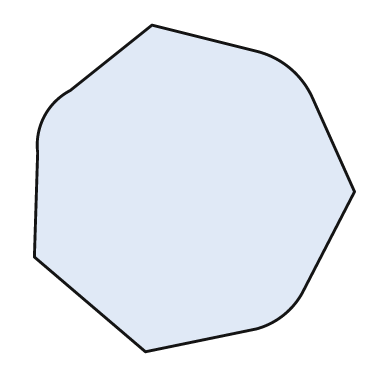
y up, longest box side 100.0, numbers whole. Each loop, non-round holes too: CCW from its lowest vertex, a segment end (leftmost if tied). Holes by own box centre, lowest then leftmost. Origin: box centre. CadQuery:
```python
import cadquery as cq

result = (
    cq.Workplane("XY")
    .moveTo(-15.0, -50.0)
    .lineTo(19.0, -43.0)
    .threePointArc((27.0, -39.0), (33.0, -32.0))
    .lineTo(49.0, -1.0)
    .lineTo(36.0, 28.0)
    .threePointArc((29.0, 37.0), (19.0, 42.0))
    .lineTo(-13.0, 50.0)
    .lineTo(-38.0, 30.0)
    .threePointArc((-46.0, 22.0), (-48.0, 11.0))
    .lineTo(-49.0, -21.0)
    .close()
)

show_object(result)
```